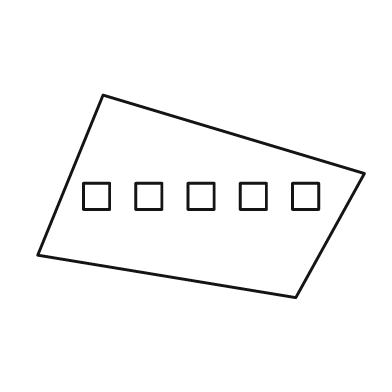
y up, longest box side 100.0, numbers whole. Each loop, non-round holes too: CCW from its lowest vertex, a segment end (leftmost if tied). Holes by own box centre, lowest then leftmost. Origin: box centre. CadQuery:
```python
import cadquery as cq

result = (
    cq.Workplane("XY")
    .moveTo(29.0, -31.0)
    .lineTo(50.0, 7.0)
    .lineTo(-30.0, 31.0)
    .lineTo(-50.0, -18.0)
    .close()
    .moveTo(-36.0, -4.0)
    .lineTo(-28.0, -4.0)
    .lineTo(-28.0, 4.0)
    .lineTo(-36.0, 4.0)
    .close()
    .moveTo(-20.0, -4.0)
    .lineTo(-12.0, -4.0)
    .lineTo(-12.0, 4.0)
    .lineTo(-20.0, 4.0)
    .close()
    .moveTo(-4.0, -4.0)
    .lineTo(4.0, -4.0)
    .lineTo(4.0, 4.0)
    .lineTo(-4.0, 4.0)
    .close()
    .moveTo(12.0, -4.0)
    .lineTo(20.0, -4.0)
    .lineTo(20.0, 4.0)
    .lineTo(12.0, 4.0)
    .close()
    .moveTo(28.0, -4.0)
    .lineTo(36.0, -4.0)
    .lineTo(36.0, 4.0)
    .lineTo(28.0, 4.0)
    .close()
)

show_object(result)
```